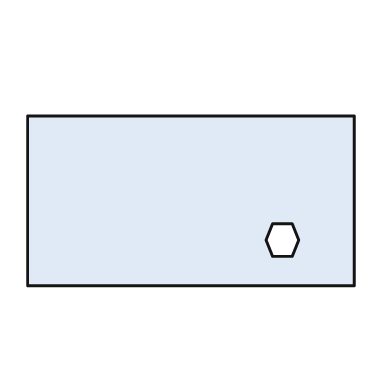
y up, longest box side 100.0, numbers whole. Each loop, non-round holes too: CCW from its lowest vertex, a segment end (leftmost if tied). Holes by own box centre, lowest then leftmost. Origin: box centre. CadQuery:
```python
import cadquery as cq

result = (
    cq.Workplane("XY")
    .moveTo(-50.0, -26.0)
    .lineTo(50.0, -26.0)
    .lineTo(50.0, 26.0)
    .lineTo(-50.0, 26.0)
    .close()
    .moveTo(25.0, -17.0)
    .lineTo(31.0, -17.0)
    .lineTo(33.0, -12.0)
    .lineTo(31.0, -7.0)
    .lineTo(25.0, -7.0)
    .lineTo(23.0, -12.0)
    .close()
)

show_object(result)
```